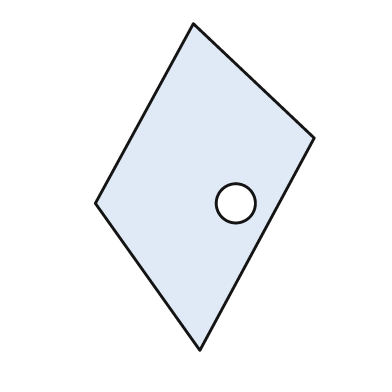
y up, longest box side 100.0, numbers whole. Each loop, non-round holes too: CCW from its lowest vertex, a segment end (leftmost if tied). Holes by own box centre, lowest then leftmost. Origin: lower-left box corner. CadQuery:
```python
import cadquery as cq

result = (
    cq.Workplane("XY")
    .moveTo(32.0, 0.0)
    .lineTo(67.0, 65.0)
    .lineTo(30.0, 100.0)
    .lineTo(0.0, 45.0)
    .close()
    .moveTo(43.0, 45.0)
    .circle(6.0)
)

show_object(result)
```